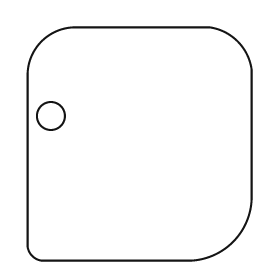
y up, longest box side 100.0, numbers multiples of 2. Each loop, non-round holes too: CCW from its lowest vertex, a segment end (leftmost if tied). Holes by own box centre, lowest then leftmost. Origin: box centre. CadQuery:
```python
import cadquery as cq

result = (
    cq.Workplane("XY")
    .moveTo(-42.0, -50.0)
    .lineTo(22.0, -50.0)
    .threePointArc((40.0, -42.0), (48.0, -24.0))
    .lineTo(48.0, 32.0)
    .threePointArc((42.0, 44.0), (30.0, 50.0))
    .lineTo(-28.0, 50.0)
    .threePointArc((-42.0, 44.0), (-48.0, 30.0))
    .lineTo(-48.0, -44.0)
    .threePointArc((-46.0, -48.0), (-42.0, -50.0))
    .close()
    .moveTo(-38.0, 12.0)
    .circle(6.0)
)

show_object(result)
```